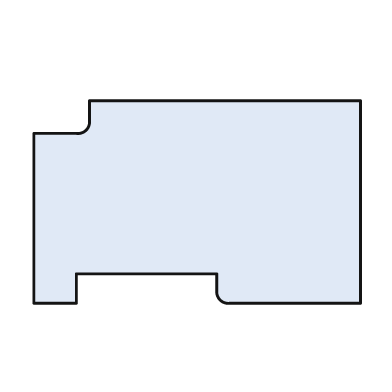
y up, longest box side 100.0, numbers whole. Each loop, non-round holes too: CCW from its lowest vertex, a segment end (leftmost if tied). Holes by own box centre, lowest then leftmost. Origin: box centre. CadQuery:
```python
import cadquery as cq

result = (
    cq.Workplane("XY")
    .moveTo(-50.0, -31.0)
    .lineTo(-37.0, -31.0)
    .lineTo(-37.0, -22.0)
    .lineTo(6.0, -22.0)
    .lineTo(6.0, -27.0)
    .threePointArc((7.0, -30.0), (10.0, -31.0))
    .lineTo(50.0, -31.0)
    .lineTo(50.0, 31.0)
    .lineTo(-33.0, 31.0)
    .lineTo(-33.0, 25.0)
    .threePointArc((-34.0, 22.0), (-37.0, 21.0))
    .lineTo(-50.0, 21.0)
    .close()
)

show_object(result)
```